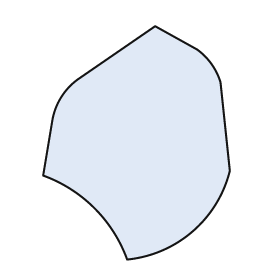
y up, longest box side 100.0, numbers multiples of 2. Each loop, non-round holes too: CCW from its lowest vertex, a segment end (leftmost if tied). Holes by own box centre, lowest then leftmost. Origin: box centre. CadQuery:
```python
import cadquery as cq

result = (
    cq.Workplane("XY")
    .moveTo(-4.0, -50.0)
    .threePointArc((24.0, -38.0), (40.0, -12.0))
    .lineTo(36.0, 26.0)
    .threePointArc((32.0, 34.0), (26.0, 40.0))
    .lineTo(8.0, 50.0)
    .lineTo(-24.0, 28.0)
    .threePointArc((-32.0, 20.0), (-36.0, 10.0))
    .lineTo(-40.0, -14.0)
    .threePointArc((-18.0, -28.0), (-4.0, -50.0))
    .close()
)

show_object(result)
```